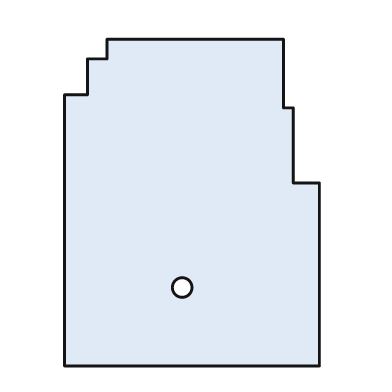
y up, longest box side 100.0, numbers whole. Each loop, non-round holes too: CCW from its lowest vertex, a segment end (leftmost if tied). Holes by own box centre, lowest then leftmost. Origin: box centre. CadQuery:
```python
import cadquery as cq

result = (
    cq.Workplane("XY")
    .moveTo(-39.0, -50.0)
    .lineTo(39.0, -50.0)
    .lineTo(39.0, 6.0)
    .lineTo(31.0, 6.0)
    .lineTo(31.0, 29.0)
    .lineTo(28.0, 29.0)
    .lineTo(28.0, 50.0)
    .lineTo(-26.0, 50.0)
    .lineTo(-26.0, 44.0)
    .lineTo(-32.0, 44.0)
    .lineTo(-32.0, 33.0)
    .lineTo(-39.0, 33.0)
    .close()
    .moveTo(-3.0, -26.0)
    .circle(3.0)
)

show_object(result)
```